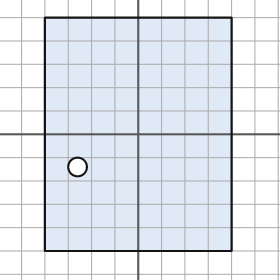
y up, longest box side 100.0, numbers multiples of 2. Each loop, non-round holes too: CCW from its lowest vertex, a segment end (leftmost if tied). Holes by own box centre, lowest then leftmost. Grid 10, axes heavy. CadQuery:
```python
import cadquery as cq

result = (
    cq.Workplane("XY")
    .moveTo(-40.0, -50.0)
    .lineTo(40.0, -50.0)
    .lineTo(40.0, 50.0)
    .lineTo(-40.0, 50.0)
    .close()
    .moveTo(-26.0, -14.0)
    .circle(4.0)
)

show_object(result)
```